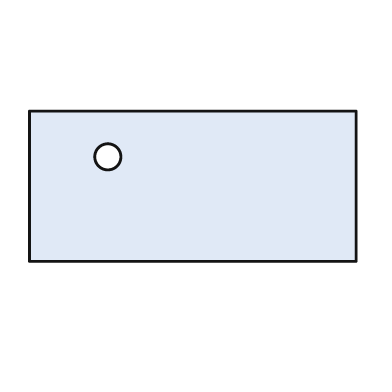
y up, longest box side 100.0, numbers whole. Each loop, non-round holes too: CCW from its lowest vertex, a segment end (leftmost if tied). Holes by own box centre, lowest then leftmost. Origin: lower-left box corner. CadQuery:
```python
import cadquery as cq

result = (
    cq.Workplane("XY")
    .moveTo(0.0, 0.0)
    .lineTo(100.0, 0.0)
    .lineTo(100.0, 46.0)
    .lineTo(0.0, 46.0)
    .close()
    .moveTo(24.0, 32.0)
    .circle(4.0)
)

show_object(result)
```